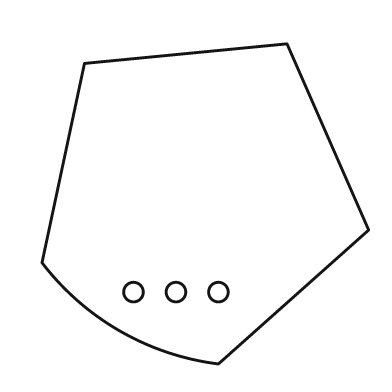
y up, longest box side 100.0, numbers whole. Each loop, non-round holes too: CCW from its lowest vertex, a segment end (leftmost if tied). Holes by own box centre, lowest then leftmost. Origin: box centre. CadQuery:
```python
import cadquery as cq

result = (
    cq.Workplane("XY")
    .moveTo(4.0, -49.0)
    .lineTo(50.0, -8.0)
    .lineTo(25.0, 49.0)
    .lineTo(-37.0, 43.0)
    .lineTo(-50.0, -18.0)
    .threePointArc((-26.0, -39.0), (4.0, -49.0))
    .close()
    .moveTo(-22.0, -27.0)
    .circle(3.0)
    .moveTo(-9.0, -27.0)
    .circle(3.0)
    .moveTo(4.0, -27.0)
    .circle(3.0)
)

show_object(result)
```